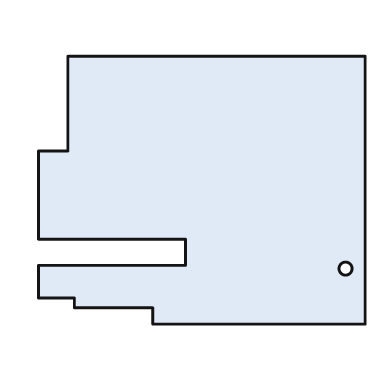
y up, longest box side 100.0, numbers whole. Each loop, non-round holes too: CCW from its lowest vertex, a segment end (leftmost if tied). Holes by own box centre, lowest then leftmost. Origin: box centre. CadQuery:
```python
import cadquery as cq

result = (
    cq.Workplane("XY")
    .moveTo(-15.0, -41.0)
    .lineTo(50.0, -41.0)
    .lineTo(50.0, 41.0)
    .lineTo(-41.0, 41.0)
    .lineTo(-41.0, 12.0)
    .lineTo(-50.0, 12.0)
    .lineTo(-50.0, -15.0)
    .lineTo(-5.0, -15.0)
    .lineTo(-5.0, -23.0)
    .lineTo(-50.0, -23.0)
    .lineTo(-50.0, -33.0)
    .lineTo(-39.0, -33.0)
    .lineTo(-39.0, -36.0)
    .lineTo(-15.0, -36.0)
    .close()
    .moveTo(44.0, -24.0)
    .circle(2.0)
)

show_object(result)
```